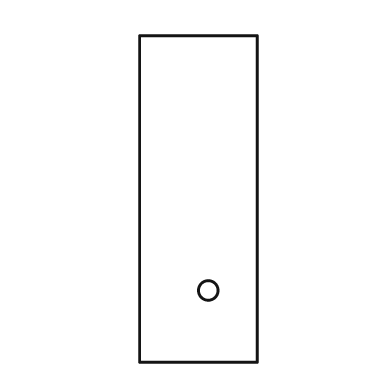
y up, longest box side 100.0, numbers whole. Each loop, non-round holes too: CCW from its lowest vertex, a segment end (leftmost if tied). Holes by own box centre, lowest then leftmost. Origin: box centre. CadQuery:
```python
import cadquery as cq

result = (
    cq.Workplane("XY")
    .moveTo(-18.0, -50.0)
    .lineTo(18.0, -50.0)
    .lineTo(18.0, 50.0)
    .lineTo(-18.0, 50.0)
    .close()
    .moveTo(3.0, -28.0)
    .circle(3.0)
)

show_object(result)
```